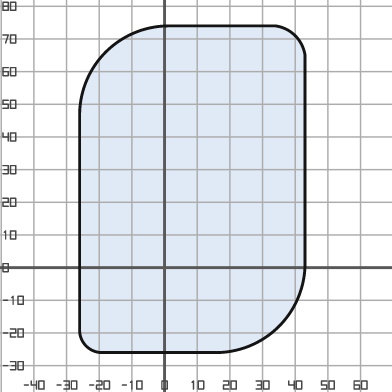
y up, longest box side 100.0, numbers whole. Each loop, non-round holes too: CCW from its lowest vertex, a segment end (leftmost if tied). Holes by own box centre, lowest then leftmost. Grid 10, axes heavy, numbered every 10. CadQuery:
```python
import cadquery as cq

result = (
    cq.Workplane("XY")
    .moveTo(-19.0, -26.0)
    .lineTo(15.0, -26.0)
    .threePointArc((35.0, -18.0), (43.0, 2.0))
    .lineTo(43.0, 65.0)
    .threePointArc((40.0, 71.0), (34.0, 74.0))
    .lineTo(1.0, 74.0)
    .threePointArc((-18.0, 66.0), (-26.0, 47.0))
    .lineTo(-26.0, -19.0)
    .threePointArc((-24.0, -24.0), (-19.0, -26.0))
    .close()
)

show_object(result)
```